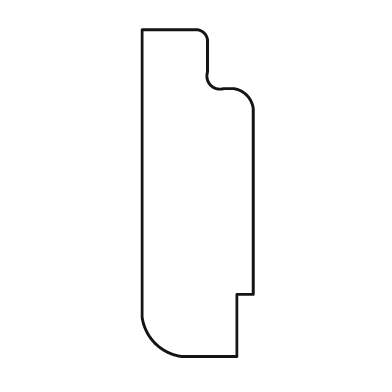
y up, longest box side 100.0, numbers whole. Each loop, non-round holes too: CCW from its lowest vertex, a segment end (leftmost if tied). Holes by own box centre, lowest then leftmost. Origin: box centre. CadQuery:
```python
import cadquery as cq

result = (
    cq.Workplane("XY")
    .moveTo(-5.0, -50.0)
    .lineTo(12.0, -50.0)
    .lineTo(12.0, -31.0)
    .lineTo(17.0, -31.0)
    .lineTo(17.0, 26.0)
    .threePointArc((15.0, 30.0), (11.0, 32.0))
    .lineTo(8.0, 32.0)
    .threePointArc((4.0, 33.0), (3.0, 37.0))
    .lineTo(3.0, 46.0)
    .threePointArc((2.0, 49.0), (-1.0, 50.0))
    .lineTo(-17.0, 50.0)
    .lineTo(-17.0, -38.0)
    .threePointArc((-13.0, -46.0), (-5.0, -50.0))
    .close()
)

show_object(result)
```